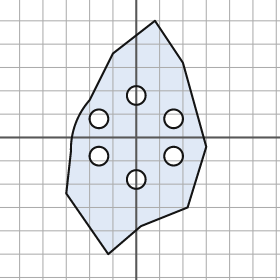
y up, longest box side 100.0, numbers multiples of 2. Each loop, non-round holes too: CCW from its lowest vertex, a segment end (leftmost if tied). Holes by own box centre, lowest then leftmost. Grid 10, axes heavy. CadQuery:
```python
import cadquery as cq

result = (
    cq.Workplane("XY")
    .moveTo(-12.0, -50.0)
    .lineTo(2.0, -38.0)
    .lineTo(22.0, -30.0)
    .lineTo(30.0, -4.0)
    .lineTo(20.0, 32.0)
    .lineTo(8.0, 50.0)
    .lineTo(-10.0, 36.0)
    .lineTo(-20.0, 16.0)
    .threePointArc((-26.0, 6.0), (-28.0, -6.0))
    .lineTo(-30.0, -24.0)
    .close()
    .moveTo(0.0, -18.0)
    .circle(4.0)
    .moveTo(-16.0, -8.0)
    .circle(4.0)
    .moveTo(16.0, -8.0)
    .circle(4.0)
    .moveTo(-16.0, 8.0)
    .circle(4.0)
    .moveTo(16.0, 8.0)
    .circle(4.0)
    .moveTo(0.0, 18.0)
    .circle(4.0)
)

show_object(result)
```